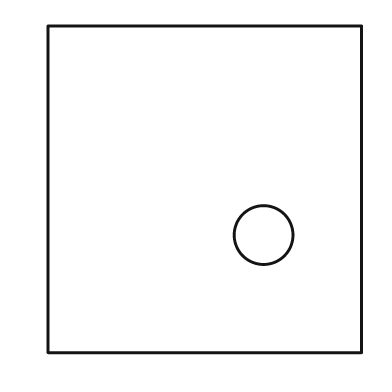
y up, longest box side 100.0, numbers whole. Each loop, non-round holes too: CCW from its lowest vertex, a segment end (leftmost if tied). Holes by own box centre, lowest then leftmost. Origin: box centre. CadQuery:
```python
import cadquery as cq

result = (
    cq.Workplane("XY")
    .moveTo(-48.0, -50.0)
    .lineTo(48.0, -50.0)
    .lineTo(48.0, 50.0)
    .lineTo(-48.0, 50.0)
    .close()
    .moveTo(18.0, -14.0)
    .circle(9.0)
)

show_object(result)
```